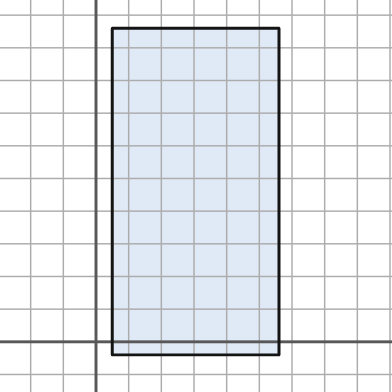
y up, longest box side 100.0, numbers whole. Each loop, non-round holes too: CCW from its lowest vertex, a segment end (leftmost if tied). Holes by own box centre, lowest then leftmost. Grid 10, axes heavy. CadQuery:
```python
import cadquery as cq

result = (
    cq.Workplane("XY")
    .moveTo(5.0, -4.0)
    .lineTo(56.0, -4.0)
    .lineTo(56.0, 96.0)
    .lineTo(5.0, 96.0)
    .close()
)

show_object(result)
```